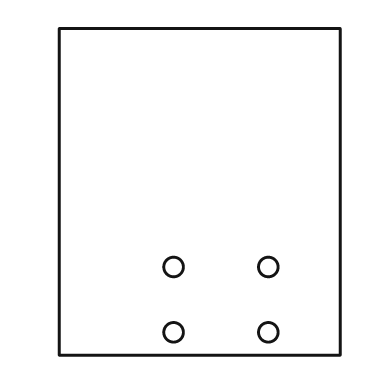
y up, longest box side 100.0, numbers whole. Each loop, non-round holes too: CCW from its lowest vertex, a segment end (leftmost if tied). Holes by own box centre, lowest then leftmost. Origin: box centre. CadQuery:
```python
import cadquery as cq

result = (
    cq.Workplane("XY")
    .moveTo(-43.0, -50.0)
    .lineTo(43.0, -50.0)
    .lineTo(43.0, 50.0)
    .lineTo(-43.0, 50.0)
    .close()
    .moveTo(-8.0, -43.0)
    .circle(3.0)
    .moveTo(21.0, -43.0)
    .circle(3.0)
    .moveTo(-8.0, -23.0)
    .circle(3.0)
    .moveTo(21.0, -23.0)
    .circle(3.0)
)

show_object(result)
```